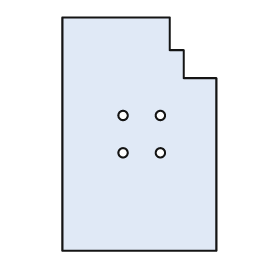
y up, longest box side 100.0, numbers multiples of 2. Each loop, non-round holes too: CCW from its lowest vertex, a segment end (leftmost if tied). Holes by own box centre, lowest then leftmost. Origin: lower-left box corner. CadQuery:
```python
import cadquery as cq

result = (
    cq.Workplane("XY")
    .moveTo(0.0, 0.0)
    .lineTo(66.0, 0.0)
    .lineTo(66.0, 74.0)
    .lineTo(52.0, 74.0)
    .lineTo(52.0, 86.0)
    .lineTo(46.0, 86.0)
    .lineTo(46.0, 100.0)
    .lineTo(0.0, 100.0)
    .close()
    .moveTo(26.0, 42.0)
    .circle(2.0)
    .moveTo(42.0, 42.0)
    .circle(2.0)
    .moveTo(26.0, 58.0)
    .circle(2.0)
    .moveTo(42.0, 58.0)
    .circle(2.0)
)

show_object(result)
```